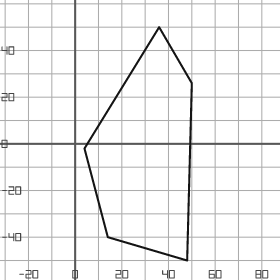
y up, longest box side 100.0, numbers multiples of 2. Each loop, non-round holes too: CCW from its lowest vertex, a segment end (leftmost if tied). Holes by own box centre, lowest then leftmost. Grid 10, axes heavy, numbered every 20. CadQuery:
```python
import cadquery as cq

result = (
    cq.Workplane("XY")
    .moveTo(48.0, -50.0)
    .lineTo(50.0, 26.0)
    .lineTo(36.0, 50.0)
    .lineTo(4.0, -2.0)
    .lineTo(14.0, -40.0)
    .close()
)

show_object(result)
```